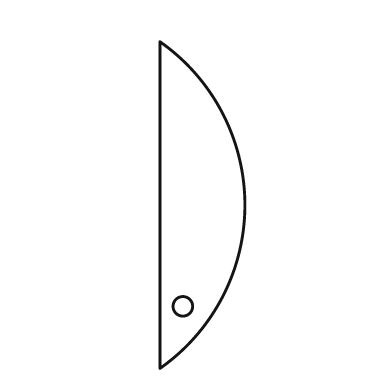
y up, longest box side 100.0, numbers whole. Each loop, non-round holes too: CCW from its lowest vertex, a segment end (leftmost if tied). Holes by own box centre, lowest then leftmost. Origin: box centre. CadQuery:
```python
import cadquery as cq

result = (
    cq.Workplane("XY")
    .moveTo(-13.0, -50.0)
    .threePointArc((13.0, 0.0), (-13.0, 50.0))
    .close()
    .moveTo(-6.0, -31.0)
    .circle(3.0)
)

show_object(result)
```